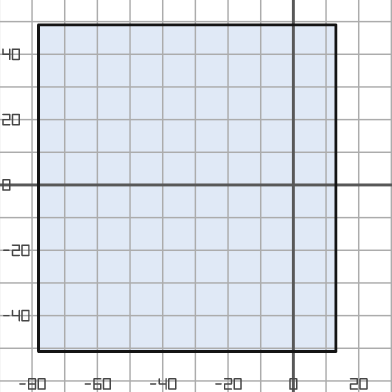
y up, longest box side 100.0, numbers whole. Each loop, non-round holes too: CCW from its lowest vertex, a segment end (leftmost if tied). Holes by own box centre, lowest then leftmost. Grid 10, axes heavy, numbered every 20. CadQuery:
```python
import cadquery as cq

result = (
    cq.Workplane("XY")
    .moveTo(-78.0, -51.0)
    .lineTo(13.0, -51.0)
    .lineTo(13.0, 49.0)
    .lineTo(-78.0, 49.0)
    .close()
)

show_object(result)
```